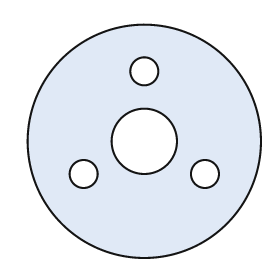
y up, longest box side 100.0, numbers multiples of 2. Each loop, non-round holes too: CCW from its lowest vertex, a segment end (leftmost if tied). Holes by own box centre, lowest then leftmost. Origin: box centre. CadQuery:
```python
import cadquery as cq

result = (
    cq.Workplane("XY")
    .moveTo(0.0, 0.0)
    .circle(50.0)
    .moveTo(-26.0, -14.0)
    .circle(6.0)
    .moveTo(26.0, -14.0)
    .circle(6.0)
    .moveTo(0.0, 0.0)
    .circle(14.0)
    .moveTo(0.0, 30.0)
    .circle(6.0)
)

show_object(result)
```